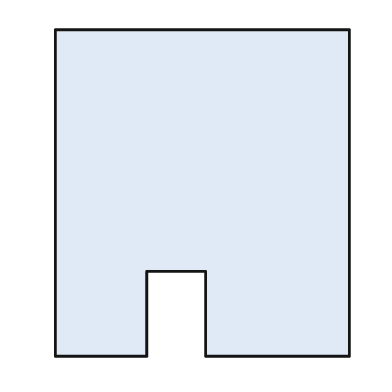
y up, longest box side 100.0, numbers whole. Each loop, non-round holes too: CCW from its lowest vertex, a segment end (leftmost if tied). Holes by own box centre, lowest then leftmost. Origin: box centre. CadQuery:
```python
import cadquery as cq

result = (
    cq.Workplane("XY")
    .moveTo(-45.0, -50.0)
    .lineTo(-17.0, -50.0)
    .lineTo(-17.0, -24.0)
    .lineTo(1.0, -24.0)
    .lineTo(1.0, -50.0)
    .lineTo(45.0, -50.0)
    .lineTo(45.0, 50.0)
    .lineTo(-45.0, 50.0)
    .close()
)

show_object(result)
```